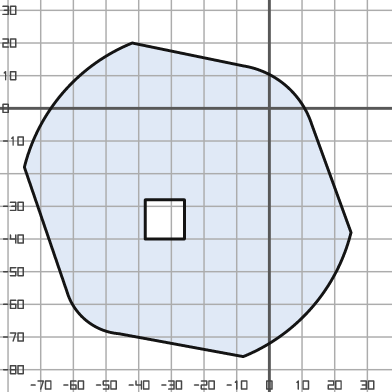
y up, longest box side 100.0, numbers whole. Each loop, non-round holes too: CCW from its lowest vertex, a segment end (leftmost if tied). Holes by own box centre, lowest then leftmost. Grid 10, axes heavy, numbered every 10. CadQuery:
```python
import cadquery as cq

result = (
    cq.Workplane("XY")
    .moveTo(-8.0, -76.0)
    .threePointArc((13.0, -61.0), (25.0, -38.0))
    .lineTo(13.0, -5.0)
    .threePointArc((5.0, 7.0), (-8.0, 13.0))
    .lineTo(-42.0, 20.0)
    .threePointArc((-63.0, 5.0), (-75.0, -18.0))
    .lineTo(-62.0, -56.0)
    .threePointArc((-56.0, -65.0), (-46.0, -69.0))
    .close()
    .moveTo(-38.0, -40.0)
    .lineTo(-26.0, -40.0)
    .lineTo(-26.0, -28.0)
    .lineTo(-38.0, -28.0)
    .close()
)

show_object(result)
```